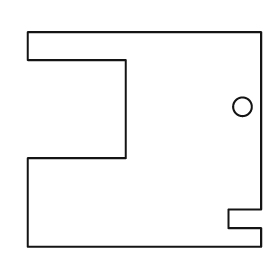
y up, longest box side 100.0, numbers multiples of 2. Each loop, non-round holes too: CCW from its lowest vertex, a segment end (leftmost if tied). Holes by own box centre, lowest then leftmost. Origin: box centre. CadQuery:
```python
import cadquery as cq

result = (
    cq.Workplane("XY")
    .moveTo(-50.0, -46.0)
    .lineTo(50.0, -46.0)
    .lineTo(50.0, -38.0)
    .lineTo(36.0, -38.0)
    .lineTo(36.0, -30.0)
    .lineTo(50.0, -30.0)
    .lineTo(50.0, 46.0)
    .lineTo(-50.0, 46.0)
    .lineTo(-50.0, 34.0)
    .lineTo(-8.0, 34.0)
    .lineTo(-8.0, -8.0)
    .lineTo(-50.0, -8.0)
    .close()
    .moveTo(42.0, 14.0)
    .circle(4.0)
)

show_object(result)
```